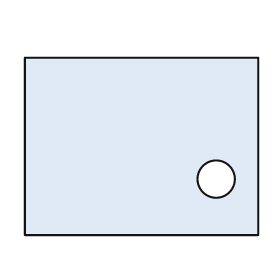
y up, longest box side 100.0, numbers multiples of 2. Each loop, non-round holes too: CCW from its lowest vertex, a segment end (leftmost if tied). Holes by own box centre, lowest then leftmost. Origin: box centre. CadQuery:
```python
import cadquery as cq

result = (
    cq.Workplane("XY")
    .moveTo(-50.0, -38.0)
    .lineTo(50.0, -38.0)
    .lineTo(50.0, 38.0)
    .lineTo(-50.0, 38.0)
    .close()
    .moveTo(32.0, -14.0)
    .circle(8.0)
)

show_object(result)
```